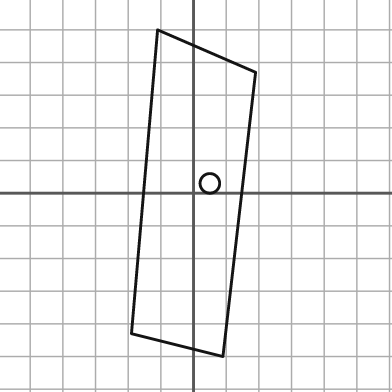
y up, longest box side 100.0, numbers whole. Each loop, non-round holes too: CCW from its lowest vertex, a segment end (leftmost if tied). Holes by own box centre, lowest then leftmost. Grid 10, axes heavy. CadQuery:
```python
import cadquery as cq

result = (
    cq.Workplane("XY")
    .moveTo(9.0, -50.0)
    .lineTo(19.0, 37.0)
    .lineTo(-11.0, 50.0)
    .lineTo(-19.0, -43.0)
    .close()
    .moveTo(5.0, 3.0)
    .circle(3.0)
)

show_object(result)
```